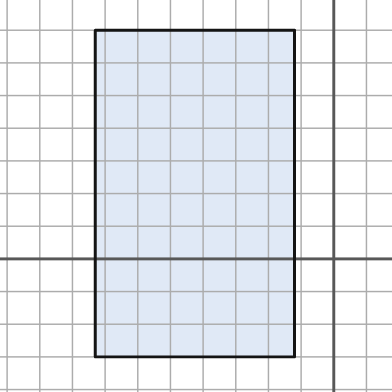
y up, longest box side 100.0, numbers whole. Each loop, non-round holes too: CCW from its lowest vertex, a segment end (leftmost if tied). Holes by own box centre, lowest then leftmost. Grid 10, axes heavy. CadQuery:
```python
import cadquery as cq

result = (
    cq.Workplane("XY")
    .moveTo(-73.0, -30.0)
    .lineTo(-12.0, -30.0)
    .lineTo(-12.0, 70.0)
    .lineTo(-73.0, 70.0)
    .close()
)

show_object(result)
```